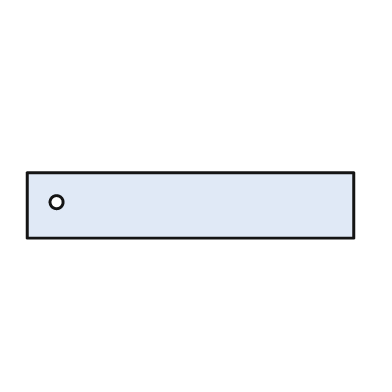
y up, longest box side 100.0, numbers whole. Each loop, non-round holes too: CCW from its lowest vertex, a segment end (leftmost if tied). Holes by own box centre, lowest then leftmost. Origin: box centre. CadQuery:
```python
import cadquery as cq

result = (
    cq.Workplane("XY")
    .moveTo(-50.0, -10.0)
    .lineTo(50.0, -10.0)
    .lineTo(50.0, 10.0)
    .lineTo(-50.0, 10.0)
    .close()
    .moveTo(-41.0, 1.0)
    .circle(2.0)
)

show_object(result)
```